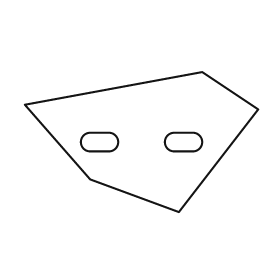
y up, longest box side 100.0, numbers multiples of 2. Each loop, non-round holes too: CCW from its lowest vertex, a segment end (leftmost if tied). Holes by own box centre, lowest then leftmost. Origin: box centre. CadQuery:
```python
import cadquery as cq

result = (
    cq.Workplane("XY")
    .moveTo(16.0, -30.0)
    .lineTo(50.0, 14.0)
    .lineTo(26.0, 30.0)
    .lineTo(-50.0, 16.0)
    .lineTo(-22.0, -16.0)
    .close()
    .moveTo(-22.0, -4.0)
    .lineTo(-14.0, -4.0)
    .threePointArc((-10.0, 0.0), (-14.0, 4.0))
    .lineTo(-22.0, 4.0)
    .threePointArc((-26.0, 0.0), (-22.0, -4.0))
    .close()
    .moveTo(14.0, -4.0)
    .lineTo(22.0, -4.0)
    .threePointArc((26.0, 0.0), (22.0, 4.0))
    .lineTo(14.0, 4.0)
    .threePointArc((10.0, 0.0), (14.0, -4.0))
    .close()
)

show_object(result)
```